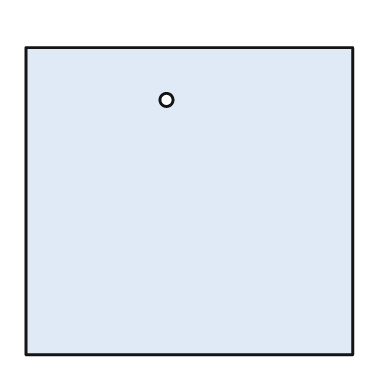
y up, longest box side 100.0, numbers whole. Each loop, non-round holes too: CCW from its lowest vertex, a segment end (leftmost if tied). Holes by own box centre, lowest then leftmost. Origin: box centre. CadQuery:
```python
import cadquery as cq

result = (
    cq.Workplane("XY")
    .moveTo(-50.0, -47.0)
    .lineTo(50.0, -47.0)
    .lineTo(50.0, 47.0)
    .lineTo(-50.0, 47.0)
    .close()
    .moveTo(-7.0, 31.0)
    .circle(2.0)
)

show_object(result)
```